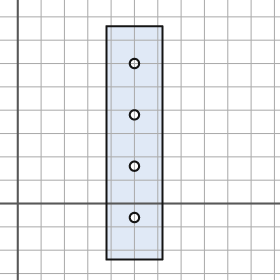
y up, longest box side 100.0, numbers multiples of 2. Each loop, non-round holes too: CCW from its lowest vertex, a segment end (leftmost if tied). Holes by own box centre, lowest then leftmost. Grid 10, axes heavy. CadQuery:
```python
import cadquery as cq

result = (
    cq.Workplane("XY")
    .moveTo(38.0, -24.0)
    .lineTo(62.0, -24.0)
    .lineTo(62.0, 76.0)
    .lineTo(38.0, 76.0)
    .close()
    .moveTo(50.0, -6.0)
    .circle(2.0)
    .moveTo(50.0, 16.0)
    .circle(2.0)
    .moveTo(50.0, 38.0)
    .circle(2.0)
    .moveTo(50.0, 60.0)
    .circle(2.0)
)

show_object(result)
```